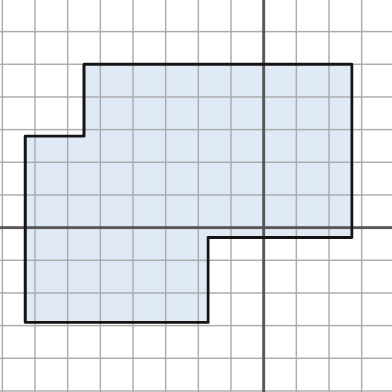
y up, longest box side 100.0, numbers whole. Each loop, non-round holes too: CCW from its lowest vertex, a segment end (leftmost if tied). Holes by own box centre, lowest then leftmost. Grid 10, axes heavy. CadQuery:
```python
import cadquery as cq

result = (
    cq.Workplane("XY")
    .moveTo(-73.0, -29.0)
    .lineTo(-17.0, -29.0)
    .lineTo(-17.0, -3.0)
    .lineTo(27.0, -3.0)
    .lineTo(27.0, 50.0)
    .lineTo(-55.0, 50.0)
    .lineTo(-55.0, 28.0)
    .lineTo(-73.0, 28.0)
    .close()
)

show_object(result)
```